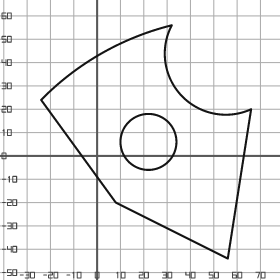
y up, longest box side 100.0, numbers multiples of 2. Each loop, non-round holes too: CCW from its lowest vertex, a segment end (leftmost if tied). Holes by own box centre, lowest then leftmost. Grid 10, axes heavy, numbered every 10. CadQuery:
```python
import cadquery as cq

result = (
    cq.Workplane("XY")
    .moveTo(56.0, -44.0)
    .lineTo(66.0, 20.0)
    .threePointArc((36.0, 26.0), (32.0, 56.0))
    .threePointArc((2.0, 44.0), (-24.0, 24.0))
    .lineTo(8.0, -20.0)
    .close()
    .moveTo(22.0, 6.0)
    .circle(12.0)
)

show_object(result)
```